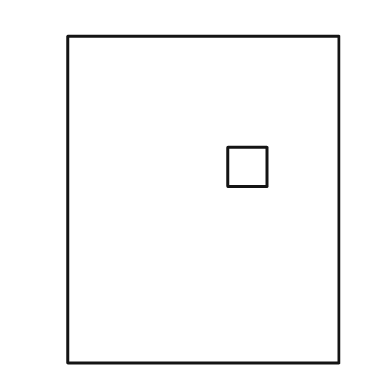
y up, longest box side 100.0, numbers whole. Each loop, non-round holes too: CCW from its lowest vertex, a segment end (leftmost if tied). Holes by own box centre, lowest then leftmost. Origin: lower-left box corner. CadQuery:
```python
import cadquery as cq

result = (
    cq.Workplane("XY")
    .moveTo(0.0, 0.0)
    .lineTo(83.0, 0.0)
    .lineTo(83.0, 100.0)
    .lineTo(0.0, 100.0)
    .close()
    .moveTo(49.0, 54.0)
    .lineTo(61.0, 54.0)
    .lineTo(61.0, 66.0)
    .lineTo(49.0, 66.0)
    .close()
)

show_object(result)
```